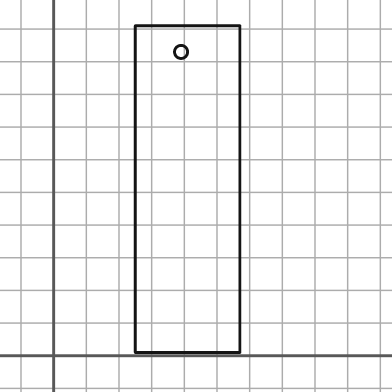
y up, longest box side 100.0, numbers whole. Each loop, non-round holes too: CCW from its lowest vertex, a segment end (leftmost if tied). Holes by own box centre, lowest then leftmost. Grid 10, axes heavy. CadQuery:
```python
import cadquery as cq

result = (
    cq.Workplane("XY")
    .moveTo(25.0, 1.0)
    .lineTo(57.0, 1.0)
    .lineTo(57.0, 101.0)
    .lineTo(25.0, 101.0)
    .close()
    .moveTo(39.0, 93.0)
    .circle(2.0)
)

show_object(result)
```